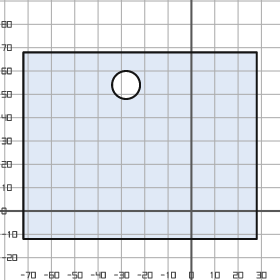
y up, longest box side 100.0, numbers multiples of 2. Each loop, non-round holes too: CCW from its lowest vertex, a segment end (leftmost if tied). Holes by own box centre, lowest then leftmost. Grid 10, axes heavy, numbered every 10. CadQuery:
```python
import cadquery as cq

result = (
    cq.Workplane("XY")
    .moveTo(-72.0, -12.0)
    .lineTo(28.0, -12.0)
    .lineTo(28.0, 68.0)
    .lineTo(-72.0, 68.0)
    .close()
    .moveTo(-28.0, 54.0)
    .circle(6.0)
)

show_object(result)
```